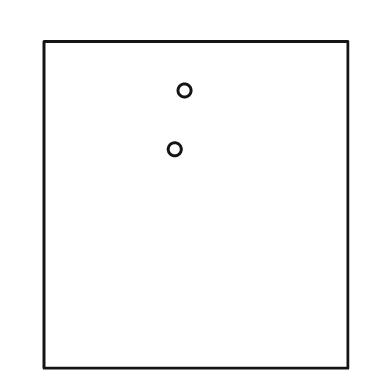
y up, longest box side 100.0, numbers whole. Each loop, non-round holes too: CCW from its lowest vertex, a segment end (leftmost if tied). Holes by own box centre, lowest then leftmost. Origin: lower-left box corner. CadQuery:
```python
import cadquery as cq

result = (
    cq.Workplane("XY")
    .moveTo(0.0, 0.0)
    .lineTo(93.0, 0.0)
    .lineTo(93.0, 100.0)
    .lineTo(0.0, 100.0)
    .close()
    .moveTo(40.0, 67.0)
    .circle(2.0)
    .moveTo(43.0, 85.0)
    .circle(2.0)
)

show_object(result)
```